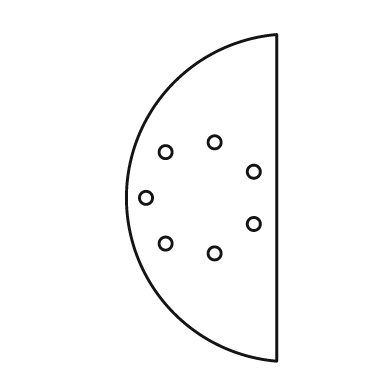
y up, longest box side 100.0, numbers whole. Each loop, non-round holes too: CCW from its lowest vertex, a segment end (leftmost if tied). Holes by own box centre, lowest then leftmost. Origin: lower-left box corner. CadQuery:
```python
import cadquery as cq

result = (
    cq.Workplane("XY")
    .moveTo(46.0, 0.0)
    .lineTo(46.0, 100.0)
    .threePointArc((0.0, 50.0), (46.0, 0.0))
    .close()
    .moveTo(27.0, 33.0)
    .circle(2.0)
    .moveTo(12.0, 36.0)
    .circle(2.0)
    .moveTo(39.0, 42.0)
    .circle(2.0)
    .moveTo(6.0, 50.0)
    .circle(2.0)
    .moveTo(39.0, 58.0)
    .circle(2.0)
    .moveTo(12.0, 64.0)
    .circle(2.0)
    .moveTo(27.0, 67.0)
    .circle(2.0)
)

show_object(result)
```